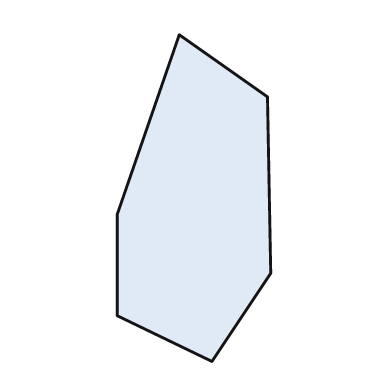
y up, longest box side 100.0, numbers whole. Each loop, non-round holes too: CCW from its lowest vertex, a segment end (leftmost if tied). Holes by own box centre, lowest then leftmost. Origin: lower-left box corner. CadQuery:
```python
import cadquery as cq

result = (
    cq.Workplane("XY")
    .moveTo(29.0, 0.0)
    .lineTo(47.0, 27.0)
    .lineTo(46.0, 81.0)
    .lineTo(19.0, 100.0)
    .lineTo(0.0, 45.0)
    .lineTo(0.0, 14.0)
    .close()
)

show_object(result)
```